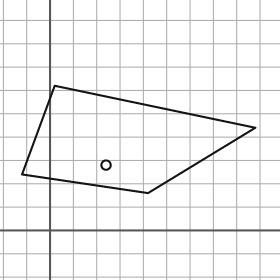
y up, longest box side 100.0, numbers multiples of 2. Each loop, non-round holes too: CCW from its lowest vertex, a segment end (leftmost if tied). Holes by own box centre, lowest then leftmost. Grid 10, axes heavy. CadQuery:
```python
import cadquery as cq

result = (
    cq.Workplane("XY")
    .moveTo(42.0, 16.0)
    .lineTo(88.0, 44.0)
    .lineTo(2.0, 62.0)
    .lineTo(-12.0, 24.0)
    .close()
    .moveTo(24.0, 28.0)
    .circle(2.0)
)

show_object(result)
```